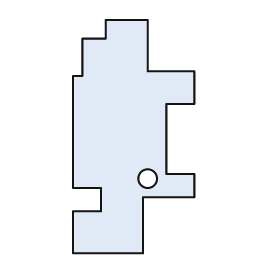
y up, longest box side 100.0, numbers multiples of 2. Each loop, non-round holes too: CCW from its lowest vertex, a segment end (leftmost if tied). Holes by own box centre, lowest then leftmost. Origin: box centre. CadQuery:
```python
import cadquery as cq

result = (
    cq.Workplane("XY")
    .moveTo(-26.0, -50.0)
    .lineTo(4.0, -50.0)
    .lineTo(4.0, -26.0)
    .lineTo(26.0, -26.0)
    .lineTo(26.0, -16.0)
    .lineTo(14.0, -16.0)
    .lineTo(14.0, 14.0)
    .lineTo(26.0, 14.0)
    .lineTo(26.0, 28.0)
    .lineTo(6.0, 28.0)
    .lineTo(6.0, 50.0)
    .lineTo(-12.0, 50.0)
    .lineTo(-12.0, 42.0)
    .lineTo(-22.0, 42.0)
    .lineTo(-22.0, 26.0)
    .lineTo(-26.0, 26.0)
    .lineTo(-26.0, -22.0)
    .lineTo(-14.0, -22.0)
    .lineTo(-14.0, -32.0)
    .lineTo(-26.0, -32.0)
    .close()
    .moveTo(6.0, -18.0)
    .circle(4.0)
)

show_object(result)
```